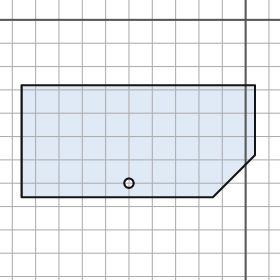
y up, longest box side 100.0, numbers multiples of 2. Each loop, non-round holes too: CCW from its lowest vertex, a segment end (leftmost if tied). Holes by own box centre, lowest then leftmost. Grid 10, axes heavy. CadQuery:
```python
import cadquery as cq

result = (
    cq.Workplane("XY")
    .moveTo(-96.0, -76.0)
    .lineTo(-14.0, -76.0)
    .lineTo(4.0, -58.0)
    .lineTo(4.0, -28.0)
    .lineTo(-96.0, -28.0)
    .close()
    .moveTo(-50.0, -70.0)
    .circle(2.0)
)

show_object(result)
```